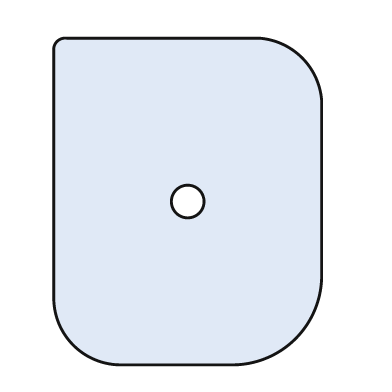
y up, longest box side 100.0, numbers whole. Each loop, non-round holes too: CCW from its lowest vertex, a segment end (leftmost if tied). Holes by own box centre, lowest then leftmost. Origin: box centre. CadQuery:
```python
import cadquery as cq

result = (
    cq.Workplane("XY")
    .moveTo(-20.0, -50.0)
    .lineTo(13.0, -50.0)
    .threePointArc((33.0, -42.0), (41.0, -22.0))
    .lineTo(41.0, 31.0)
    .threePointArc((35.0, 44.0), (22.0, 50.0))
    .lineTo(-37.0, 50.0)
    .threePointArc((-40.0, 49.0), (-41.0, 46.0))
    .lineTo(-41.0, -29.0)
    .threePointArc((-35.0, -44.0), (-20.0, -50.0))
    .close()
    .moveTo(0.0, 0.0)
    .circle(5.0)
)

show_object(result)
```